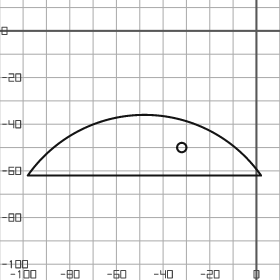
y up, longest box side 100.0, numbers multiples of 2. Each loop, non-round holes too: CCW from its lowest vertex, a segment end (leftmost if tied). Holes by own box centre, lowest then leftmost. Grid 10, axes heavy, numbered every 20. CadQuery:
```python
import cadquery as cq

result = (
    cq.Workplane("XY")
    .moveTo(-98.0, -62.0)
    .lineTo(2.0, -62.0)
    .threePointArc((-48.0, -36.0), (-98.0, -62.0))
    .close()
    .moveTo(-32.0, -50.0)
    .circle(2.0)
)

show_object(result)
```